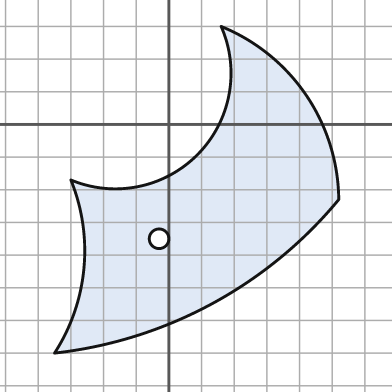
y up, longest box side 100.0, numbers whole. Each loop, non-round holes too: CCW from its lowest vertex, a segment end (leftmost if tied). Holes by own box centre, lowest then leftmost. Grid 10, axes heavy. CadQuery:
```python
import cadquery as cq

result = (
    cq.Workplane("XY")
    .moveTo(-35.0, -70.0)
    .threePointArc((13.0, -55.0), (52.0, -23.0))
    .threePointArc((42.0, 9.0), (16.0, 30.0))
    .threePointArc((9.0, -9.0), (-30.0, -17.0))
    .threePointArc((-26.0, -44.0), (-35.0, -70.0))
    .close()
    .moveTo(-3.0, -35.0)
    .circle(3.0)
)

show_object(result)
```